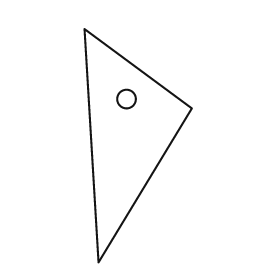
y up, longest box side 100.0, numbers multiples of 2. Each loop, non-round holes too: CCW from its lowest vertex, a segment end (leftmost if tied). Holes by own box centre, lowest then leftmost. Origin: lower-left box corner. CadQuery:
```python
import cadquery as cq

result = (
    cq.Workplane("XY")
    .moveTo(6.0, 0.0)
    .lineTo(46.0, 66.0)
    .lineTo(0.0, 100.0)
    .close()
    .moveTo(18.0, 70.0)
    .circle(4.0)
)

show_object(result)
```